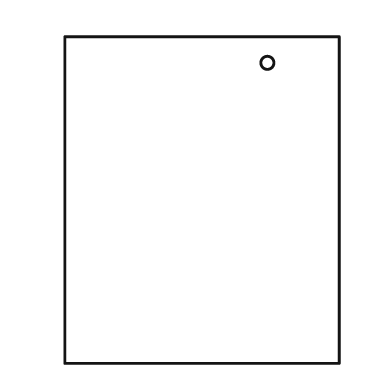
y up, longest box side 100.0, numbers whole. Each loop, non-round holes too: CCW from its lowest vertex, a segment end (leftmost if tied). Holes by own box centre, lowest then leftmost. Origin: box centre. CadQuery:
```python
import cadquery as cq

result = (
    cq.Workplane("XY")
    .moveTo(-42.0, -50.0)
    .lineTo(42.0, -50.0)
    .lineTo(42.0, 50.0)
    .lineTo(-42.0, 50.0)
    .close()
    .moveTo(20.0, 42.0)
    .circle(2.0)
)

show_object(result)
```